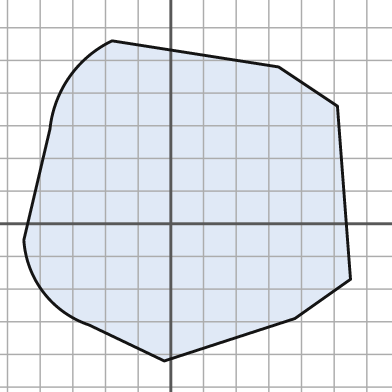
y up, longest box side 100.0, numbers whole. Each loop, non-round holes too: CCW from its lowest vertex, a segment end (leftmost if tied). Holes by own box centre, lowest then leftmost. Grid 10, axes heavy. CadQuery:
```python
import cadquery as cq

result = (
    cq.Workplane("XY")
    .moveTo(-2.0, -42.0)
    .lineTo(38.0, -29.0)
    .lineTo(55.0, -17.0)
    .lineTo(51.0, 36.0)
    .lineTo(33.0, 48.0)
    .lineTo(-18.0, 56.0)
    .threePointArc((-31.0, 45.0), (-37.0, 29.0))
    .lineTo(-45.0, -5.0)
    .threePointArc((-39.0, -21.0), (-25.0, -31.0))
    .close()
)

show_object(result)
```